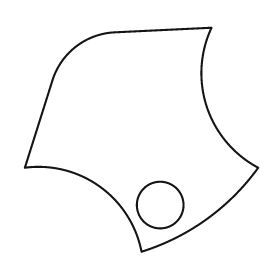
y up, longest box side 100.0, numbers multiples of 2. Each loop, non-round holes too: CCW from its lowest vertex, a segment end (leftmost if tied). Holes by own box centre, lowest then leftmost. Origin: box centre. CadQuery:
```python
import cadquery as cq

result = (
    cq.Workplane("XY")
    .moveTo(0.0, -48.0)
    .threePointArc((28.0, -34.0), (50.0, -12.0))
    .threePointArc((28.0, 14.0), (30.0, 48.0))
    .lineTo(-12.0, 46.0)
    .threePointArc((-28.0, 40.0), (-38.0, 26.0))
    .lineTo(-50.0, -12.0)
    .threePointArc((-18.0, -20.0), (0.0, -48.0))
    .close()
    .moveTo(8.0, -28.0)
    .circle(10.0)
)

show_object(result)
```